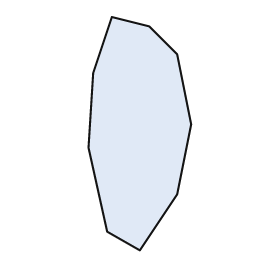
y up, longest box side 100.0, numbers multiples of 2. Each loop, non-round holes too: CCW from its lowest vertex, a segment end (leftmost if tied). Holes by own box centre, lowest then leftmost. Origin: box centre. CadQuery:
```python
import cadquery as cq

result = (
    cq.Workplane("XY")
    .moveTo(0.0, -50.0)
    .lineTo(16.0, -26.0)
    .lineTo(22.0, 4.0)
    .lineTo(16.0, 34.0)
    .lineTo(4.0, 46.0)
    .lineTo(-12.0, 50.0)
    .lineTo(-20.0, 26.0)
    .lineTo(-22.0, -6.0)
    .lineTo(-14.0, -42.0)
    .close()
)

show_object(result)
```